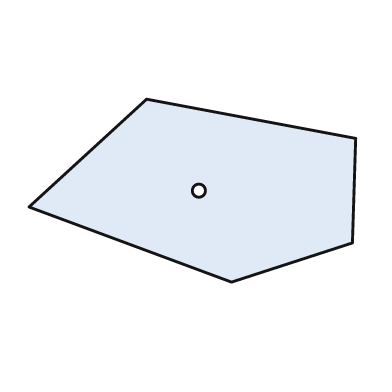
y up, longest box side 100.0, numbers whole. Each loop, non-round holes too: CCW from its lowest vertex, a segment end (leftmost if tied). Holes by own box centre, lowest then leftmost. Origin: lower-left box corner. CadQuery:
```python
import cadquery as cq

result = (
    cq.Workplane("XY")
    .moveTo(62.0, 0.0)
    .lineTo(99.0, 12.0)
    .lineTo(100.0, 44.0)
    .lineTo(36.0, 56.0)
    .lineTo(0.0, 23.0)
    .close()
    .moveTo(52.0, 28.0)
    .circle(2.0)
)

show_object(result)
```